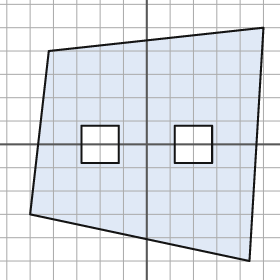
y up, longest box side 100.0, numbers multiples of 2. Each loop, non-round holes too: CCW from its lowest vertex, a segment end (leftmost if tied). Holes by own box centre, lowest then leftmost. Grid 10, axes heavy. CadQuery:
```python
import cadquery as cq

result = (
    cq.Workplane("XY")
    .moveTo(44.0, -50.0)
    .lineTo(50.0, 50.0)
    .lineTo(-42.0, 40.0)
    .lineTo(-50.0, -30.0)
    .close()
    .moveTo(-28.0, -8.0)
    .lineTo(-12.0, -8.0)
    .lineTo(-12.0, 8.0)
    .lineTo(-28.0, 8.0)
    .close()
    .moveTo(12.0, -8.0)
    .lineTo(28.0, -8.0)
    .lineTo(28.0, 8.0)
    .lineTo(12.0, 8.0)
    .close()
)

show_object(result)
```